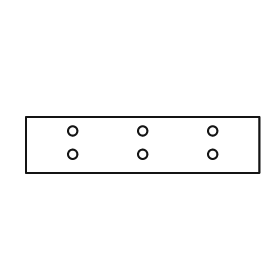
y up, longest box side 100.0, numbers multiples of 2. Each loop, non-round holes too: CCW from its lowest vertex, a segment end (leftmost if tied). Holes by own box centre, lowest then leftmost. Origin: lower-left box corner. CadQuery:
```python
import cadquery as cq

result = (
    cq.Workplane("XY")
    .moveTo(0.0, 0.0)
    .lineTo(100.0, 0.0)
    .lineTo(100.0, 24.0)
    .lineTo(0.0, 24.0)
    .close()
    .moveTo(20.0, 8.0)
    .circle(2.0)
    .moveTo(50.0, 8.0)
    .circle(2.0)
    .moveTo(80.0, 8.0)
    .circle(2.0)
    .moveTo(20.0, 18.0)
    .circle(2.0)
    .moveTo(50.0, 18.0)
    .circle(2.0)
    .moveTo(80.0, 18.0)
    .circle(2.0)
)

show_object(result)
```